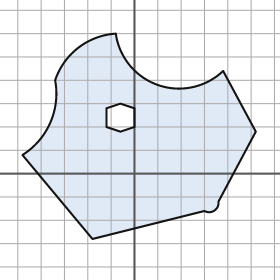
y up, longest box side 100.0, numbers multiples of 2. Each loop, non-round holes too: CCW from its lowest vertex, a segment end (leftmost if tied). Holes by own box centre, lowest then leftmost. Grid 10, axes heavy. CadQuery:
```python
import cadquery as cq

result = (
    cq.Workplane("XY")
    .moveTo(-18.0, -28.0)
    .lineTo(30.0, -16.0)
    .threePointArc((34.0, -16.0), (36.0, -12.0))
    .lineTo(52.0, 18.0)
    .lineTo(38.0, 44.0)
    .threePointArc((10.0, 38.0), (-8.0, 60.0))
    .threePointArc((-24.0, 54.0), (-34.0, 40.0))
    .threePointArc((-36.0, 22.0), (-48.0, 8.0))
    .close()
    .moveTo(-6.0, 18.0)
    .lineTo(0.0, 20.0)
    .lineTo(0.0, 28.0)
    .lineTo(-6.0, 30.0)
    .lineTo(-12.0, 28.0)
    .lineTo(-12.0, 20.0)
    .close()
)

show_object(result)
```